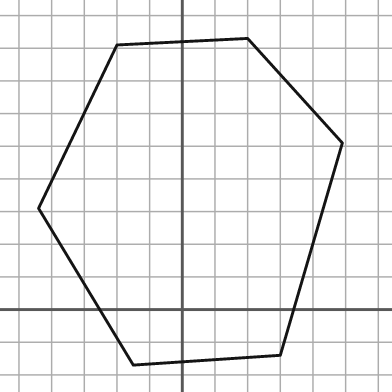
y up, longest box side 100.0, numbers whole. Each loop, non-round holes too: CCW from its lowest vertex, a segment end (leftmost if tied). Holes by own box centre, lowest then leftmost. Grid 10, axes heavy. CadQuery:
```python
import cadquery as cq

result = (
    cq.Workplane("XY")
    .moveTo(-15.0, -17.0)
    .lineTo(30.0, -14.0)
    .lineTo(49.0, 51.0)
    .lineTo(20.0, 83.0)
    .lineTo(-20.0, 81.0)
    .lineTo(-44.0, 31.0)
    .close()
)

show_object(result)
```